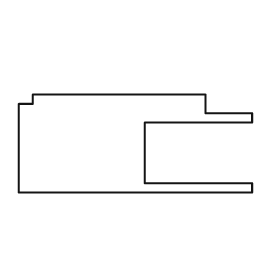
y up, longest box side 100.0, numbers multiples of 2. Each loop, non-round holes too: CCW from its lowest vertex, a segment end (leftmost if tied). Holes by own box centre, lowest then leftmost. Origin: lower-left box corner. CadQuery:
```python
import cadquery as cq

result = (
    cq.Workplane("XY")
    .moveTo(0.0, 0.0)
    .lineTo(100.0, 0.0)
    .lineTo(100.0, 4.0)
    .lineTo(54.0, 4.0)
    .lineTo(54.0, 30.0)
    .lineTo(100.0, 30.0)
    .lineTo(100.0, 34.0)
    .lineTo(80.0, 34.0)
    .lineTo(80.0, 42.0)
    .lineTo(6.0, 42.0)
    .lineTo(6.0, 38.0)
    .lineTo(0.0, 38.0)
    .close()
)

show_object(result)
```